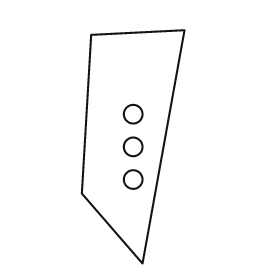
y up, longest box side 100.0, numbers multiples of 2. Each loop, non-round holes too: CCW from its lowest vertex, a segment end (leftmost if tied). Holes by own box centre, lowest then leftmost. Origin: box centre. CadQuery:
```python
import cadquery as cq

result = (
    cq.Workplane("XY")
    .moveTo(4.0, -50.0)
    .lineTo(22.0, 50.0)
    .lineTo(-18.0, 48.0)
    .lineTo(-22.0, -20.0)
    .close()
    .moveTo(0.0, -14.0)
    .circle(4.0)
    .moveTo(0.0, 0.0)
    .circle(4.0)
    .moveTo(0.0, 14.0)
    .circle(4.0)
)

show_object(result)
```